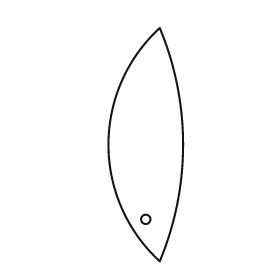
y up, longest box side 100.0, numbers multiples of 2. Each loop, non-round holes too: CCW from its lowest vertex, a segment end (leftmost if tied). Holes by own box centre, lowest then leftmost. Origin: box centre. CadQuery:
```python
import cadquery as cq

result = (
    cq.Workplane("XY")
    .moveTo(6.0, -50.0)
    .threePointArc((16.0, 0.0), (6.0, 50.0))
    .threePointArc((-16.0, 0.0), (6.0, -50.0))
    .close()
    .moveTo(0.0, -32.0)
    .circle(2.0)
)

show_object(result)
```